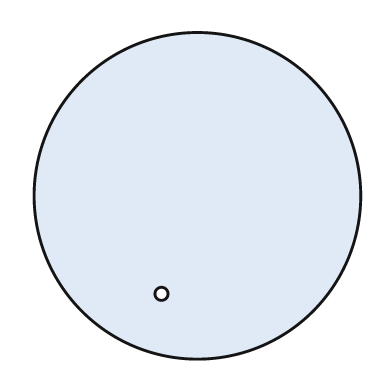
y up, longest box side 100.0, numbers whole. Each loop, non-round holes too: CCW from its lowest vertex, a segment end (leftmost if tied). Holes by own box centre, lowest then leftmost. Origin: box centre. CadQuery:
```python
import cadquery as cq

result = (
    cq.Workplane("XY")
    .moveTo(0.0, 0.0)
    .circle(50.0)
    .moveTo(-11.0, -30.0)
    .circle(2.0)
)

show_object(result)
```